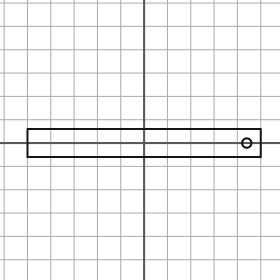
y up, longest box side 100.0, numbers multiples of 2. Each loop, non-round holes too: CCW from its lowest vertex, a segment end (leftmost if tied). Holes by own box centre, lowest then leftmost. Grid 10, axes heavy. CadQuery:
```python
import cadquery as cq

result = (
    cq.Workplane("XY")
    .moveTo(-50.0, -6.0)
    .lineTo(50.0, -6.0)
    .lineTo(50.0, 6.0)
    .lineTo(-50.0, 6.0)
    .close()
    .moveTo(44.0, 0.0)
    .circle(2.0)
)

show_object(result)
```